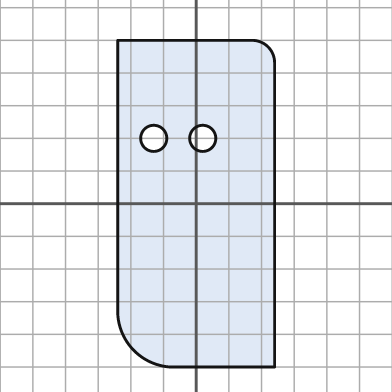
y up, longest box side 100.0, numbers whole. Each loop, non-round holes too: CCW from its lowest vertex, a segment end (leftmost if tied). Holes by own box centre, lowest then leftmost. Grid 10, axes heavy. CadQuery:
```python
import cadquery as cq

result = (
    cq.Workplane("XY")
    .moveTo(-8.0, -50.0)
    .lineTo(24.0, -50.0)
    .lineTo(24.0, 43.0)
    .threePointArc((22.0, 48.0), (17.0, 50.0))
    .lineTo(-24.0, 50.0)
    .lineTo(-24.0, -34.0)
    .threePointArc((-19.0, -45.0), (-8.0, -50.0))
    .close()
    .moveTo(-13.0, 20.0)
    .circle(4.0)
    .moveTo(2.0, 20.0)
    .circle(4.0)
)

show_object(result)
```